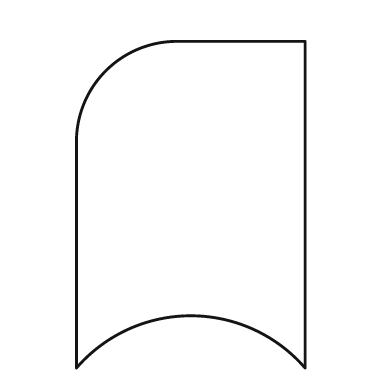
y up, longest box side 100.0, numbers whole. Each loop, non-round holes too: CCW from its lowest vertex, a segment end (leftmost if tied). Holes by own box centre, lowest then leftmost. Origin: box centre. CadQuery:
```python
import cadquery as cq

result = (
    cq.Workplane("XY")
    .moveTo(-35.0, -50.0)
    .threePointArc((0.0, -34.0), (35.0, -50.0))
    .lineTo(35.0, 50.0)
    .lineTo(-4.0, 50.0)
    .threePointArc((-26.0, 41.0), (-35.0, 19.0))
    .close()
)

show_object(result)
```